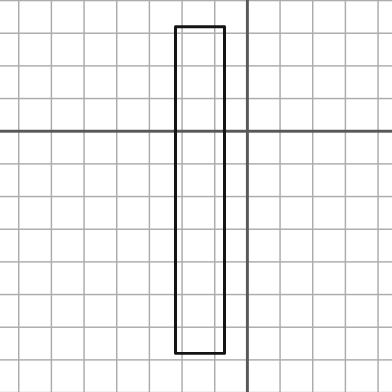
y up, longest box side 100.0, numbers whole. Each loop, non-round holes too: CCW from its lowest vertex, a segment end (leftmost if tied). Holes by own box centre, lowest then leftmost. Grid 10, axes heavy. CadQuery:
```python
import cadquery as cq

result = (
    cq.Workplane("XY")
    .moveTo(-22.0, -68.0)
    .lineTo(-7.0, -68.0)
    .lineTo(-7.0, 32.0)
    .lineTo(-22.0, 32.0)
    .close()
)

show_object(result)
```